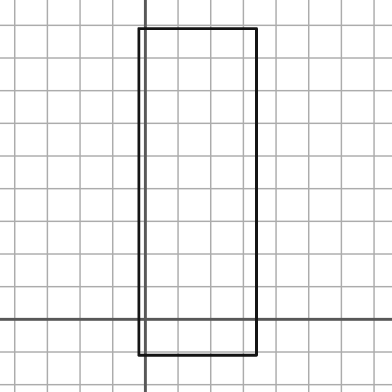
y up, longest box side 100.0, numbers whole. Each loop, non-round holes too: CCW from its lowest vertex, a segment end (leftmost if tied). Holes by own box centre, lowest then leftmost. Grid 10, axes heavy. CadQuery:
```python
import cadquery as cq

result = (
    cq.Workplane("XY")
    .moveTo(-2.0, -11.0)
    .lineTo(34.0, -11.0)
    .lineTo(34.0, 89.0)
    .lineTo(-2.0, 89.0)
    .close()
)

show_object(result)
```